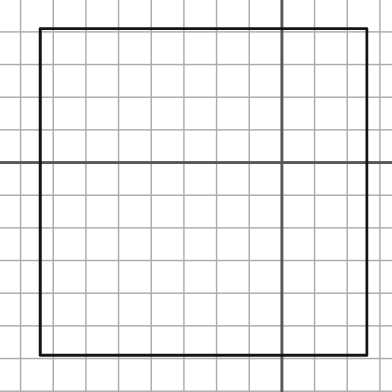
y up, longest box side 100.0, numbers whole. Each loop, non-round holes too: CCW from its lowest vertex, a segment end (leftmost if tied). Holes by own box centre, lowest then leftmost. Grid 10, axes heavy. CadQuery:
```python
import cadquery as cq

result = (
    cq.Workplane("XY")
    .moveTo(-74.0, -59.0)
    .lineTo(26.0, -59.0)
    .lineTo(26.0, 41.0)
    .lineTo(-74.0, 41.0)
    .close()
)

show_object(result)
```